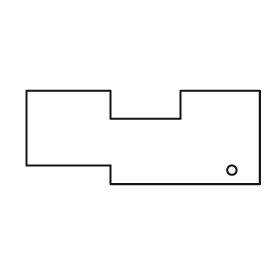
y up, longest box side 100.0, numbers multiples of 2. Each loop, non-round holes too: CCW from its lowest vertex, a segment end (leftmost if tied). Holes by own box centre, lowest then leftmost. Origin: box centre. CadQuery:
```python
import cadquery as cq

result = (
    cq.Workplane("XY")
    .moveTo(-14.0, -20.0)
    .lineTo(50.0, -20.0)
    .lineTo(50.0, 20.0)
    .lineTo(16.0, 20.0)
    .lineTo(16.0, 8.0)
    .lineTo(-14.0, 8.0)
    .lineTo(-14.0, 20.0)
    .lineTo(-50.0, 20.0)
    .lineTo(-50.0, -12.0)
    .lineTo(-14.0, -12.0)
    .close()
    .moveTo(38.0, -14.0)
    .circle(2.0)
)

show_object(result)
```